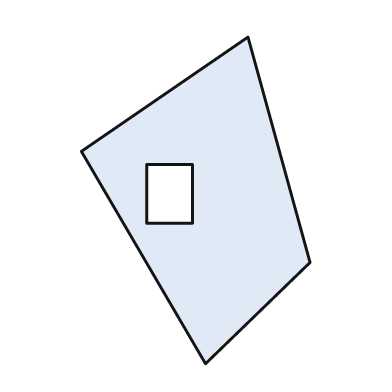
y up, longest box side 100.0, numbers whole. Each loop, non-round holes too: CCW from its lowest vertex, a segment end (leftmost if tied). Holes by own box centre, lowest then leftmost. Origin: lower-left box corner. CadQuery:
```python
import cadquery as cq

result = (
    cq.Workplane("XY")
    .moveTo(38.0, 0.0)
    .lineTo(70.0, 31.0)
    .lineTo(51.0, 100.0)
    .lineTo(0.0, 65.0)
    .close()
    .moveTo(20.0, 43.0)
    .lineTo(34.0, 43.0)
    .lineTo(34.0, 61.0)
    .lineTo(20.0, 61.0)
    .close()
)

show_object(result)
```